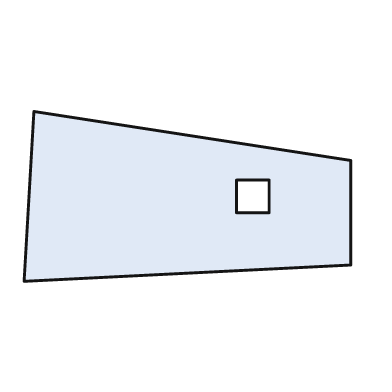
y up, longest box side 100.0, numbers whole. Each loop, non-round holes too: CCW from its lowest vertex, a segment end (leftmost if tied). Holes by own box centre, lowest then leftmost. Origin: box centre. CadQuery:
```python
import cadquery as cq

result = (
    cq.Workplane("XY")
    .moveTo(-50.0, -26.0)
    .lineTo(50.0, -21.0)
    .lineTo(50.0, 11.0)
    .lineTo(-47.0, 26.0)
    .close()
    .moveTo(15.0, -5.0)
    .lineTo(25.0, -5.0)
    .lineTo(25.0, 5.0)
    .lineTo(15.0, 5.0)
    .close()
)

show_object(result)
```